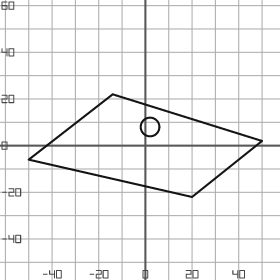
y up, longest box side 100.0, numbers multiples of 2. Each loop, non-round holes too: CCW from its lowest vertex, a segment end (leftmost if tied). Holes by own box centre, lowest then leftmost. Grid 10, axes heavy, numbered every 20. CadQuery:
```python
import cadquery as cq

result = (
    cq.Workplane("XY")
    .moveTo(20.0, -22.0)
    .lineTo(50.0, 2.0)
    .lineTo(-14.0, 22.0)
    .lineTo(-50.0, -6.0)
    .close()
    .moveTo(2.0, 8.0)
    .circle(4.0)
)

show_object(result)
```